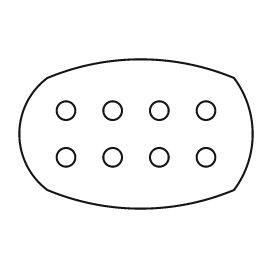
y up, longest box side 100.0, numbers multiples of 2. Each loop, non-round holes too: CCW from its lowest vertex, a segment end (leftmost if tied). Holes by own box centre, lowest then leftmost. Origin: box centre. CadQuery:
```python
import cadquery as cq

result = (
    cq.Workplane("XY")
    .moveTo(-38.0, -24.0)
    .threePointArc((2.0, -32.0), (42.0, -24.0))
    .threePointArc((50.0, 0.0), (42.0, 24.0))
    .threePointArc((2.0, 32.0), (-38.0, 24.0))
    .threePointArc((-50.0, 0.0), (-38.0, -24.0))
    .close()
    .moveTo(-30.0, -10.0)
    .circle(4.0)
    .moveTo(-10.0, -10.0)
    .circle(4.0)
    .moveTo(10.0, -10.0)
    .circle(4.0)
    .moveTo(30.0, -10.0)
    .circle(4.0)
    .moveTo(-30.0, 10.0)
    .circle(4.0)
    .moveTo(-10.0, 10.0)
    .circle(4.0)
    .moveTo(10.0, 10.0)
    .circle(4.0)
    .moveTo(30.0, 10.0)
    .circle(4.0)
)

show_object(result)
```